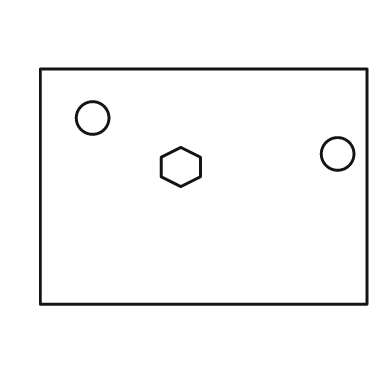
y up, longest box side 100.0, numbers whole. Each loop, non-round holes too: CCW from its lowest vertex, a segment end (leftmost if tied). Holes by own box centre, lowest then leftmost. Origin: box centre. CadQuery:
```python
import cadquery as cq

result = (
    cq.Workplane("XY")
    .moveTo(-50.0, -36.0)
    .lineTo(50.0, -36.0)
    .lineTo(50.0, 36.0)
    .lineTo(-50.0, 36.0)
    .close()
    .moveTo(-7.0, 0.0)
    .lineTo(-1.0, 3.0)
    .lineTo(-1.0, 9.0)
    .lineTo(-7.0, 12.0)
    .lineTo(-13.0, 9.0)
    .lineTo(-13.0, 3.0)
    .close()
    .moveTo(41.0, 10.0)
    .circle(5.0)
    .moveTo(-34.0, 21.0)
    .circle(5.0)
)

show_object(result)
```